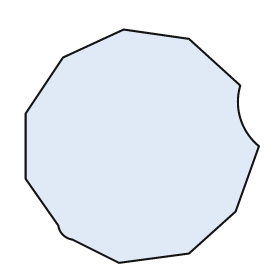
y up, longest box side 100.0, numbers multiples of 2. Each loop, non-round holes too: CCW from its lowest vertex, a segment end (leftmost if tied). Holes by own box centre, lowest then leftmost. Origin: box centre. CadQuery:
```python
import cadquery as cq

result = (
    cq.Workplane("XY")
    .moveTo(-10.0, -50.0)
    .lineTo(20.0, -46.0)
    .lineTo(40.0, -28.0)
    .lineTo(50.0, 0.0)
    .threePointArc((42.0, 12.0), (42.0, 26.0))
    .lineTo(20.0, 46.0)
    .lineTo(-8.0, 50.0)
    .lineTo(-34.0, 38.0)
    .lineTo(-50.0, 14.0)
    .lineTo(-50.0, -14.0)
    .lineTo(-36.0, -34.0)
    .threePointArc((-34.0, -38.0), (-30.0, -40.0))
    .close()
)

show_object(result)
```